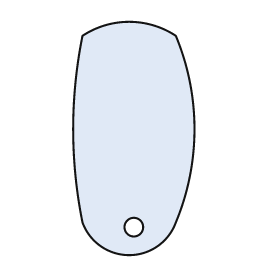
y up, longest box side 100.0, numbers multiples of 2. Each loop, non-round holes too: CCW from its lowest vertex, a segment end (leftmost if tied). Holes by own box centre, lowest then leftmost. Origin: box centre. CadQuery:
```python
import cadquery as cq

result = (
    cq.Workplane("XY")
    .moveTo(-22.0, -36.0)
    .threePointArc((-2.0, -50.0), (18.0, -36.0))
    .threePointArc((26.0, 4.0), (18.0, 44.0))
    .threePointArc((-2.0, 50.0), (-22.0, 44.0))
    .threePointArc((-26.0, 4.0), (-22.0, -36.0))
    .close()
    .moveTo(0.0, -38.0)
    .circle(4.0)
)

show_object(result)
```